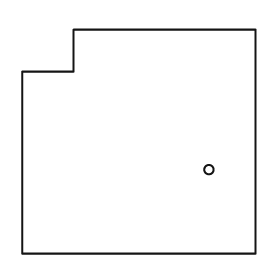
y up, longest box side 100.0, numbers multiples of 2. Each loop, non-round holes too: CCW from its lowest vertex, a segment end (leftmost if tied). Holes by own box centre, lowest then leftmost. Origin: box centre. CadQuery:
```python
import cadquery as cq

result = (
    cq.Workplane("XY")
    .moveTo(-50.0, -48.0)
    .lineTo(50.0, -48.0)
    .lineTo(50.0, 48.0)
    .lineTo(-28.0, 48.0)
    .lineTo(-28.0, 30.0)
    .lineTo(-50.0, 30.0)
    .close()
    .moveTo(30.0, -12.0)
    .circle(2.0)
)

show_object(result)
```